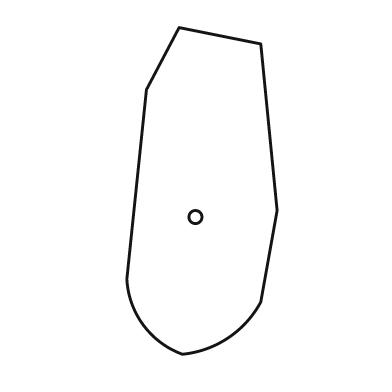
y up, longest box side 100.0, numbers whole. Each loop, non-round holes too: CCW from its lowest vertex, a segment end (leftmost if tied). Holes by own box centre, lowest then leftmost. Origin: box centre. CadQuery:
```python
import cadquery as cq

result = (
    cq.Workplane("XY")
    .moveTo(-6.0, -50.0)
    .threePointArc((8.0, -45.0), (18.0, -34.0))
    .lineTo(23.0, -6.0)
    .lineTo(18.0, 45.0)
    .lineTo(-7.0, 50.0)
    .lineTo(-17.0, 31.0)
    .lineTo(-23.0, -27.0)
    .threePointArc((-18.0, -41.0), (-6.0, -50.0))
    .close()
    .moveTo(-2.0, -8.0)
    .circle(2.0)
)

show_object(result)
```